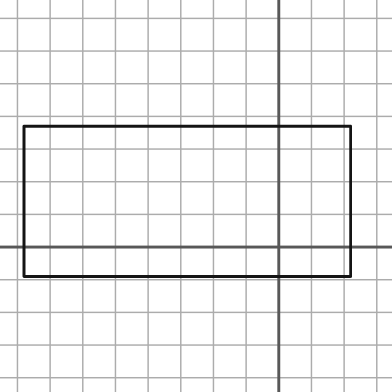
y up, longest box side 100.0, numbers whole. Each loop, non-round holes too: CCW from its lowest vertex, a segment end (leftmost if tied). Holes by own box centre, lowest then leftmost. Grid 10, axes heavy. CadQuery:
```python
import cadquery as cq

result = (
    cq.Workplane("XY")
    .moveTo(-78.0, -9.0)
    .lineTo(22.0, -9.0)
    .lineTo(22.0, 37.0)
    .lineTo(-78.0, 37.0)
    .close()
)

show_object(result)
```